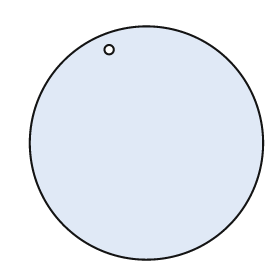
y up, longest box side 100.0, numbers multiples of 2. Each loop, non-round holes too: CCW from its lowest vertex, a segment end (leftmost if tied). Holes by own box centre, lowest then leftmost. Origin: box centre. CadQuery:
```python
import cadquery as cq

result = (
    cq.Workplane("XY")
    .moveTo(0.0, 0.0)
    .circle(50.0)
    .moveTo(-16.0, 40.0)
    .circle(2.0)
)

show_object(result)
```